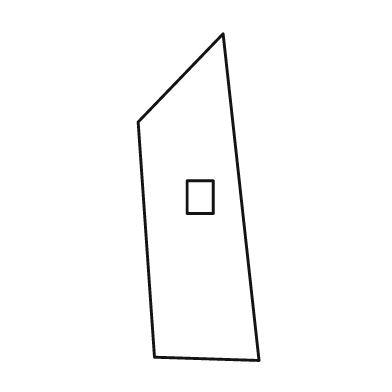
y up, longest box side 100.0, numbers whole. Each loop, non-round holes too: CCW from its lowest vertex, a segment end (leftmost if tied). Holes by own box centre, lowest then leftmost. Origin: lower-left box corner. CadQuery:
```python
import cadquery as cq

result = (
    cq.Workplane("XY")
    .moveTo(37.0, 0.0)
    .lineTo(26.0, 100.0)
    .lineTo(0.0, 73.0)
    .lineTo(5.0, 1.0)
    .close()
    .moveTo(15.0, 45.0)
    .lineTo(23.0, 45.0)
    .lineTo(23.0, 55.0)
    .lineTo(15.0, 55.0)
    .close()
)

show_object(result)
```